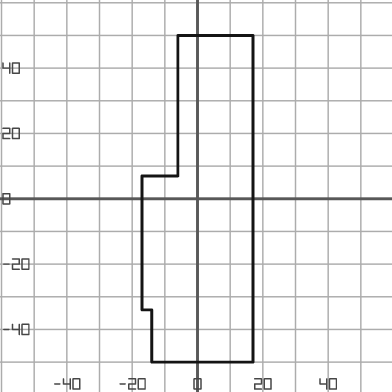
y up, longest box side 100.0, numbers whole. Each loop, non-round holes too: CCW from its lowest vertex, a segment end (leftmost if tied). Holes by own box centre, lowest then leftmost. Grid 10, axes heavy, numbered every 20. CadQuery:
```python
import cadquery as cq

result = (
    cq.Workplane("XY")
    .moveTo(-14.0, -50.0)
    .lineTo(17.0, -50.0)
    .lineTo(17.0, 50.0)
    .lineTo(-6.0, 50.0)
    .lineTo(-6.0, 7.0)
    .lineTo(-17.0, 7.0)
    .lineTo(-17.0, -34.0)
    .lineTo(-14.0, -34.0)
    .close()
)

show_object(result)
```